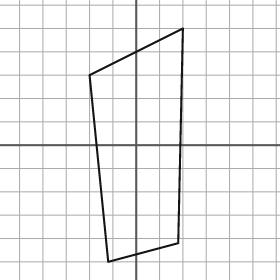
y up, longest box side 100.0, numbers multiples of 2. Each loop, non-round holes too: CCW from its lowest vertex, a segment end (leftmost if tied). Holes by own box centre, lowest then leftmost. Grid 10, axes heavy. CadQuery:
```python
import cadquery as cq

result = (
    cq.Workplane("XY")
    .moveTo(-12.0, -50.0)
    .lineTo(18.0, -42.0)
    .lineTo(20.0, 50.0)
    .lineTo(-20.0, 30.0)
    .close()
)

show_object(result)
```